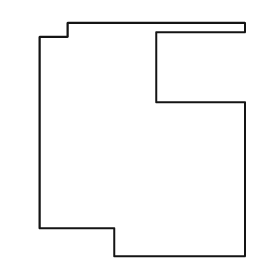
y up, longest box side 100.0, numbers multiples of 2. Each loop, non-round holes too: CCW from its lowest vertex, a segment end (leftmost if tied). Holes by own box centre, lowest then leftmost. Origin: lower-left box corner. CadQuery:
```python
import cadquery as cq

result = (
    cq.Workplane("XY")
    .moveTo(32.0, 0.0)
    .lineTo(88.0, 0.0)
    .lineTo(88.0, 66.0)
    .lineTo(50.0, 66.0)
    .lineTo(50.0, 96.0)
    .lineTo(88.0, 96.0)
    .lineTo(88.0, 100.0)
    .lineTo(12.0, 100.0)
    .lineTo(12.0, 94.0)
    .lineTo(0.0, 94.0)
    .lineTo(0.0, 12.0)
    .lineTo(32.0, 12.0)
    .close()
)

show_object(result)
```